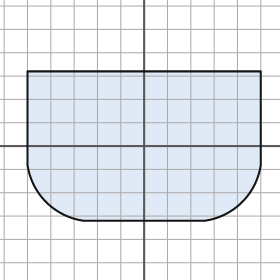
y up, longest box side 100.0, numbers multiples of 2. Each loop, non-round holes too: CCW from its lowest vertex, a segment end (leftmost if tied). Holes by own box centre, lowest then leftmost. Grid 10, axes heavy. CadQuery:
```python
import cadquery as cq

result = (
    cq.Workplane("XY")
    .moveTo(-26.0, -32.0)
    .lineTo(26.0, -32.0)
    .threePointArc((42.0, -24.0), (50.0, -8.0))
    .lineTo(50.0, 32.0)
    .lineTo(-50.0, 32.0)
    .lineTo(-50.0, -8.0)
    .threePointArc((-42.0, -24.0), (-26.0, -32.0))
    .close()
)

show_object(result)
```